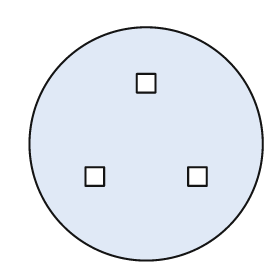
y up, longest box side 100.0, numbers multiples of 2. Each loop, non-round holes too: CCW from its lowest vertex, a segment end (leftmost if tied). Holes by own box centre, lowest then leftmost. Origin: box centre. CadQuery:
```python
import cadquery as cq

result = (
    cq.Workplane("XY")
    .moveTo(0.0, 0.0)
    .circle(50.0)
    .moveTo(-26.0, -18.0)
    .lineTo(-18.0, -18.0)
    .lineTo(-18.0, -10.0)
    .lineTo(-26.0, -10.0)
    .close()
    .moveTo(18.0, -18.0)
    .lineTo(26.0, -18.0)
    .lineTo(26.0, -10.0)
    .lineTo(18.0, -10.0)
    .close()
    .moveTo(-4.0, 22.0)
    .lineTo(4.0, 22.0)
    .lineTo(4.0, 30.0)
    .lineTo(-4.0, 30.0)
    .close()
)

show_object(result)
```